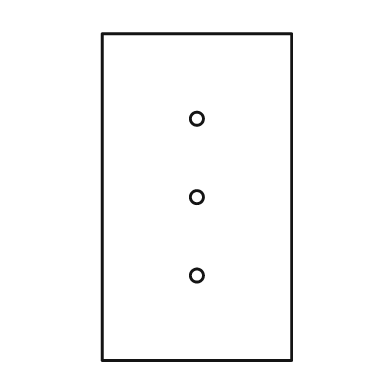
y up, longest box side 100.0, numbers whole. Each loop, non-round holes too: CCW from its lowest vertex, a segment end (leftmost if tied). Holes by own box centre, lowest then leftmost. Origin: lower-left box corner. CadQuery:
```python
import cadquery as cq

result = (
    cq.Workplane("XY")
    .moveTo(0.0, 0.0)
    .lineTo(58.0, 0.0)
    .lineTo(58.0, 100.0)
    .lineTo(0.0, 100.0)
    .close()
    .moveTo(29.0, 26.0)
    .circle(2.0)
    .moveTo(29.0, 50.0)
    .circle(2.0)
    .moveTo(29.0, 74.0)
    .circle(2.0)
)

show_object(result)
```